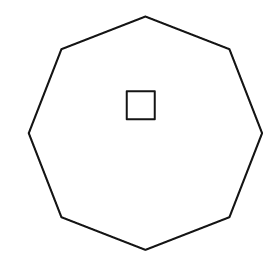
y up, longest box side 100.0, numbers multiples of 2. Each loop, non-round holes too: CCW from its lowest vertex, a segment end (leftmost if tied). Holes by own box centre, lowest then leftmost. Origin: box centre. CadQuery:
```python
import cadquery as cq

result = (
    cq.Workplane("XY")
    .moveTo(0.0, -50.0)
    .lineTo(36.0, -36.0)
    .lineTo(50.0, 0.0)
    .lineTo(36.0, 36.0)
    .lineTo(0.0, 50.0)
    .lineTo(-36.0, 36.0)
    .lineTo(-50.0, 0.0)
    .lineTo(-36.0, -36.0)
    .close()
    .moveTo(-8.0, 6.0)
    .lineTo(4.0, 6.0)
    .lineTo(4.0, 18.0)
    .lineTo(-8.0, 18.0)
    .close()
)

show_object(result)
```